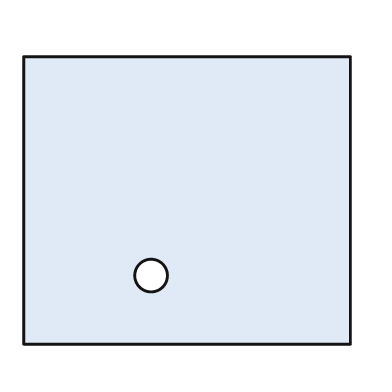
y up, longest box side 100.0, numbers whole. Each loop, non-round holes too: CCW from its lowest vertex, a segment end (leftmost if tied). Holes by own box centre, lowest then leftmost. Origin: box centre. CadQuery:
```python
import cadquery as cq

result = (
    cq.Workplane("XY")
    .moveTo(-50.0, -44.0)
    .lineTo(50.0, -44.0)
    .lineTo(50.0, 44.0)
    .lineTo(-50.0, 44.0)
    .close()
    .moveTo(-11.0, -23.0)
    .circle(5.0)
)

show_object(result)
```